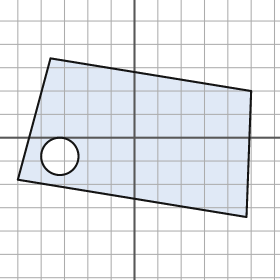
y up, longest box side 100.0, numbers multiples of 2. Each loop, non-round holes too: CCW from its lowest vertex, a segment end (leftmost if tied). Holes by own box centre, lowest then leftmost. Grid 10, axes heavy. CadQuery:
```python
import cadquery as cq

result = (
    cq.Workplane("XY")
    .moveTo(48.0, -34.0)
    .lineTo(50.0, 20.0)
    .lineTo(-36.0, 34.0)
    .lineTo(-50.0, -18.0)
    .close()
    .moveTo(-32.0, -8.0)
    .circle(8.0)
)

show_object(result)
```